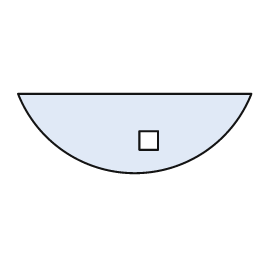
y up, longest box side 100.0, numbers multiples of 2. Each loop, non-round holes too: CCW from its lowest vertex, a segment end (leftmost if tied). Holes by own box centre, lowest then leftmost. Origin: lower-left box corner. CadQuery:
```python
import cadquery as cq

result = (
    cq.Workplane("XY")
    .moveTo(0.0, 34.0)
    .threePointArc((50.0, 0.0), (100.0, 34.0))
    .close()
    .moveTo(52.0, 10.0)
    .lineTo(60.0, 10.0)
    .lineTo(60.0, 18.0)
    .lineTo(52.0, 18.0)
    .close()
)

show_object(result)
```